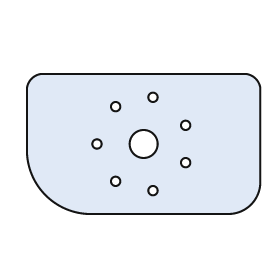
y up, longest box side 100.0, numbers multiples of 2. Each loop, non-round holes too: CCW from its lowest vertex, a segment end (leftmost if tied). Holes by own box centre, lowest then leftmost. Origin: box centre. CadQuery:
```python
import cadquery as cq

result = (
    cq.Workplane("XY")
    .moveTo(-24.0, -30.0)
    .lineTo(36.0, -30.0)
    .threePointArc((46.0, -26.0), (50.0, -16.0))
    .lineTo(50.0, 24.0)
    .threePointArc((48.0, 28.0), (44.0, 30.0))
    .lineTo(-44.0, 30.0)
    .threePointArc((-48.0, 28.0), (-50.0, 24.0))
    .lineTo(-50.0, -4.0)
    .threePointArc((-42.0, -22.0), (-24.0, -30.0))
    .close()
    .moveTo(4.0, -20.0)
    .circle(2.0)
    .moveTo(-12.0, -16.0)
    .circle(2.0)
    .moveTo(18.0, -8.0)
    .circle(2.0)
    .moveTo(-20.0, 0.0)
    .circle(2.0)
    .moveTo(0.0, 0.0)
    .circle(6.0)
    .moveTo(18.0, 8.0)
    .circle(2.0)
    .moveTo(-12.0, 16.0)
    .circle(2.0)
    .moveTo(4.0, 20.0)
    .circle(2.0)
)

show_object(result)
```